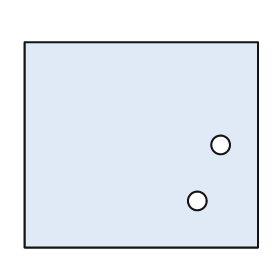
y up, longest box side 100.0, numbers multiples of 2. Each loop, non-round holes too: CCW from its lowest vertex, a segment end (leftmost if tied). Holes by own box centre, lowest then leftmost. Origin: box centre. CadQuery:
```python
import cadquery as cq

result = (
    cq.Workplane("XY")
    .moveTo(-50.0, -44.0)
    .lineTo(50.0, -44.0)
    .lineTo(50.0, 44.0)
    .lineTo(-50.0, 44.0)
    .close()
    .moveTo(24.0, -24.0)
    .circle(4.0)
    .moveTo(34.0, 0.0)
    .circle(4.0)
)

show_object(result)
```